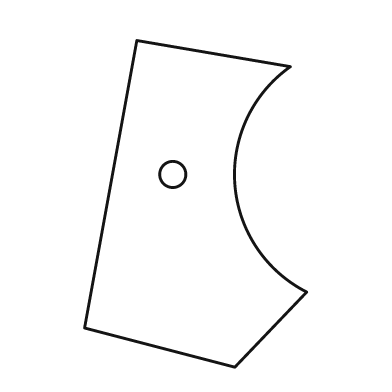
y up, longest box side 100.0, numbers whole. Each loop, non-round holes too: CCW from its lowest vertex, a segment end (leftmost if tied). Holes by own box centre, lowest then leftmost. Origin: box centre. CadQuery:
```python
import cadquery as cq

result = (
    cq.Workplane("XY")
    .moveTo(12.0, -50.0)
    .lineTo(34.0, -27.0)
    .threePointArc((12.0, 6.0), (29.0, 42.0))
    .lineTo(-18.0, 50.0)
    .lineTo(-34.0, -38.0)
    .close()
    .moveTo(-7.0, 9.0)
    .circle(4.0)
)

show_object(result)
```